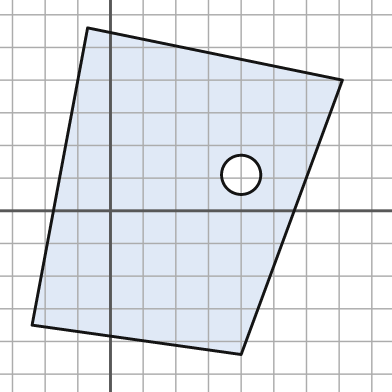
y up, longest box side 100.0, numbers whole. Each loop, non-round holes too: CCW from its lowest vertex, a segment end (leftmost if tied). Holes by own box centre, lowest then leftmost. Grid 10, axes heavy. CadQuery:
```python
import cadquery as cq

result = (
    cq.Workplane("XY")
    .moveTo(40.0, -44.0)
    .lineTo(71.0, 40.0)
    .lineTo(-7.0, 56.0)
    .lineTo(-24.0, -35.0)
    .close()
    .moveTo(40.0, 11.0)
    .circle(6.0)
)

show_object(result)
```